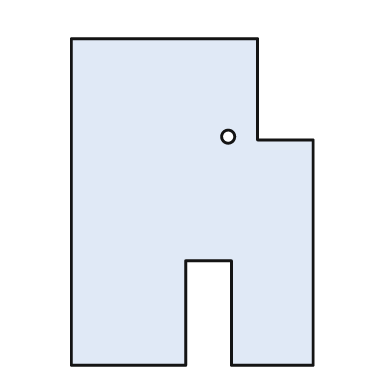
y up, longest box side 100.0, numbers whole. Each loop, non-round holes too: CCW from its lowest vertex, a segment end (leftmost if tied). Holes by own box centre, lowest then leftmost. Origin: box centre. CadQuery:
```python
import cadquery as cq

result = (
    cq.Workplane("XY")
    .moveTo(-37.0, -50.0)
    .lineTo(-2.0, -50.0)
    .lineTo(-2.0, -18.0)
    .lineTo(12.0, -18.0)
    .lineTo(12.0, -50.0)
    .lineTo(37.0, -50.0)
    .lineTo(37.0, 19.0)
    .lineTo(20.0, 19.0)
    .lineTo(20.0, 50.0)
    .lineTo(-37.0, 50.0)
    .close()
    .moveTo(11.0, 20.0)
    .circle(2.0)
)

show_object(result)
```